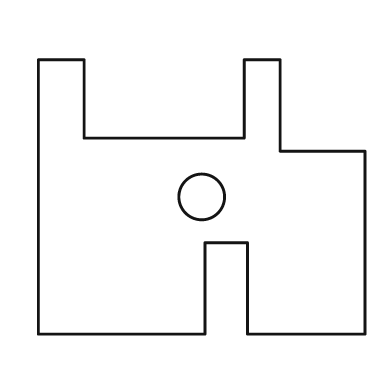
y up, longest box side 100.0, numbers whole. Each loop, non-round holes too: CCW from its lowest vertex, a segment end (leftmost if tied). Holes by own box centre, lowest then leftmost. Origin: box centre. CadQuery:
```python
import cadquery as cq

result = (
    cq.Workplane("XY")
    .moveTo(-50.0, -42.0)
    .lineTo(1.0, -42.0)
    .lineTo(1.0, -14.0)
    .lineTo(14.0, -14.0)
    .lineTo(14.0, -42.0)
    .lineTo(50.0, -42.0)
    .lineTo(50.0, 14.0)
    .lineTo(24.0, 14.0)
    .lineTo(24.0, 42.0)
    .lineTo(13.0, 42.0)
    .lineTo(13.0, 18.0)
    .lineTo(-36.0, 18.0)
    .lineTo(-36.0, 42.0)
    .lineTo(-50.0, 42.0)
    .close()
    .moveTo(0.0, 0.0)
    .circle(7.0)
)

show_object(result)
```